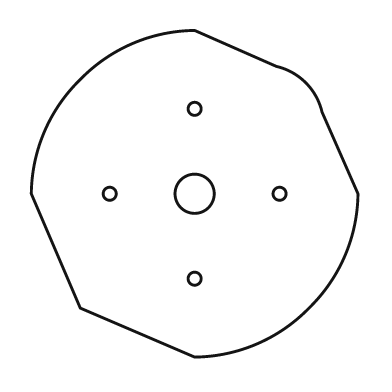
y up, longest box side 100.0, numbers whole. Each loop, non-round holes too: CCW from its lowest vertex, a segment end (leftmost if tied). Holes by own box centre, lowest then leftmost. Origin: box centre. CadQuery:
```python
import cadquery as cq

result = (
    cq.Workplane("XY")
    .moveTo(0.0, -50.0)
    .threePointArc((19.0, -46.0), (35.0, -35.0))
    .threePointArc((46.0, -19.0), (50.0, 0.0))
    .lineTo(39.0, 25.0)
    .threePointArc((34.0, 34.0), (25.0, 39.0))
    .lineTo(0.0, 50.0)
    .threePointArc((-19.0, 46.0), (-35.0, 35.0))
    .threePointArc((-46.0, 19.0), (-50.0, 0.0))
    .lineTo(-35.0, -35.0)
    .close()
    .moveTo(0.0, -26.0)
    .circle(2.0)
    .moveTo(-26.0, 0.0)
    .circle(2.0)
    .moveTo(0.0, 0.0)
    .circle(6.0)
    .moveTo(26.0, 0.0)
    .circle(2.0)
    .moveTo(0.0, 26.0)
    .circle(2.0)
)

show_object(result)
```